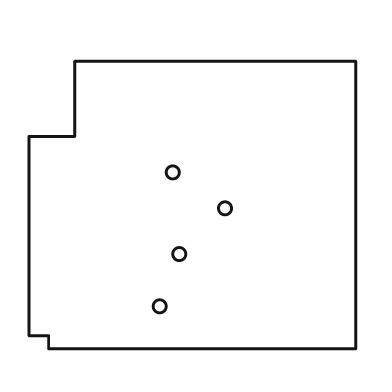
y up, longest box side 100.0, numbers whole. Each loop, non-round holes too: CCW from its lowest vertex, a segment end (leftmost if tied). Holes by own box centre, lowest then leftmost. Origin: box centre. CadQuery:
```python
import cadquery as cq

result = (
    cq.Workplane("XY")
    .moveTo(-44.0, -44.0)
    .lineTo(50.0, -44.0)
    .lineTo(50.0, 44.0)
    .lineTo(-36.0, 44.0)
    .lineTo(-36.0, 21.0)
    .lineTo(-50.0, 21.0)
    .lineTo(-50.0, -40.0)
    .lineTo(-44.0, -40.0)
    .close()
    .moveTo(-10.0, -31.0)
    .circle(2.0)
    .moveTo(-4.0, -15.0)
    .circle(2.0)
    .moveTo(10.0, -1.0)
    .circle(2.0)
    .moveTo(-6.0, 10.0)
    .circle(2.0)
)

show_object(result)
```